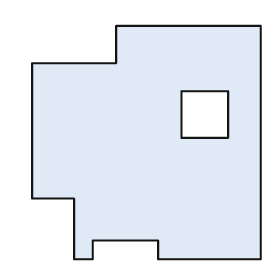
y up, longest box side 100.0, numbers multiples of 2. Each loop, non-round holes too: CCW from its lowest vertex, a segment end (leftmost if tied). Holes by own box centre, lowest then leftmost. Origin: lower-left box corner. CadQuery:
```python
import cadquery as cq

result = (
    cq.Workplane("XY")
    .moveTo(18.0, 0.0)
    .lineTo(26.0, 0.0)
    .lineTo(26.0, 8.0)
    .lineTo(54.0, 8.0)
    .lineTo(54.0, 0.0)
    .lineTo(98.0, 0.0)
    .lineTo(98.0, 100.0)
    .lineTo(36.0, 100.0)
    .lineTo(36.0, 84.0)
    .lineTo(0.0, 84.0)
    .lineTo(0.0, 26.0)
    .lineTo(18.0, 26.0)
    .close()
    .moveTo(64.0, 52.0)
    .lineTo(84.0, 52.0)
    .lineTo(84.0, 72.0)
    .lineTo(64.0, 72.0)
    .close()
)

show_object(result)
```